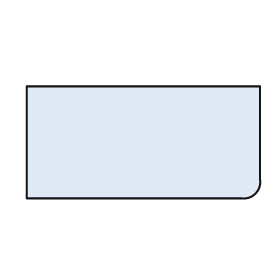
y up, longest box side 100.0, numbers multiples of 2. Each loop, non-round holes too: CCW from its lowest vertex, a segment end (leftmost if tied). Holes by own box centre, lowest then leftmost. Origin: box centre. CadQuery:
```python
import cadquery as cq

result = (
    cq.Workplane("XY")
    .moveTo(-50.0, -24.0)
    .lineTo(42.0, -24.0)
    .threePointArc((48.0, -22.0), (50.0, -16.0))
    .lineTo(50.0, 24.0)
    .lineTo(-50.0, 24.0)
    .close()
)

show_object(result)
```